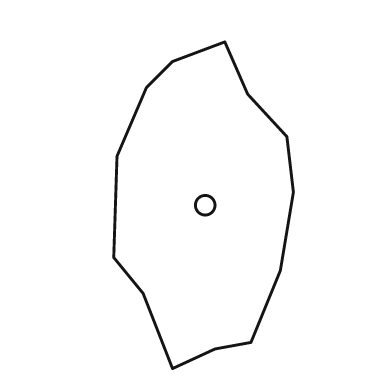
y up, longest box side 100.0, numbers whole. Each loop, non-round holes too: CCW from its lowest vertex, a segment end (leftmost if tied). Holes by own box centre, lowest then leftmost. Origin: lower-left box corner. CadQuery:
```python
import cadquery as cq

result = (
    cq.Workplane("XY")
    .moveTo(18.0, 0.0)
    .lineTo(31.0, 6.0)
    .lineTo(42.0, 8.0)
    .lineTo(51.0, 30.0)
    .lineTo(55.0, 54.0)
    .lineTo(53.0, 71.0)
    .lineTo(41.0, 84.0)
    .lineTo(34.0, 100.0)
    .lineTo(18.0, 94.0)
    .lineTo(10.0, 86.0)
    .lineTo(1.0, 65.0)
    .lineTo(0.0, 34.0)
    .lineTo(9.0, 23.0)
    .close()
    .moveTo(28.0, 50.0)
    .circle(3.0)
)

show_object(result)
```